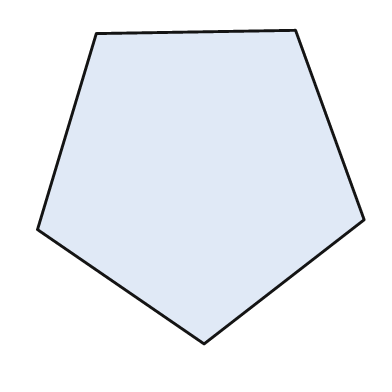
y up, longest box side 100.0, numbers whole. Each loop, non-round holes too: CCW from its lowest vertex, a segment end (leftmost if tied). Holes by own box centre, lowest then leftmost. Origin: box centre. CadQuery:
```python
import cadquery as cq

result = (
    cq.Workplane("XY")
    .moveTo(1.0, -48.0)
    .lineTo(50.0, -10.0)
    .lineTo(29.0, 48.0)
    .lineTo(-32.0, 47.0)
    .lineTo(-50.0, -13.0)
    .close()
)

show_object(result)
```